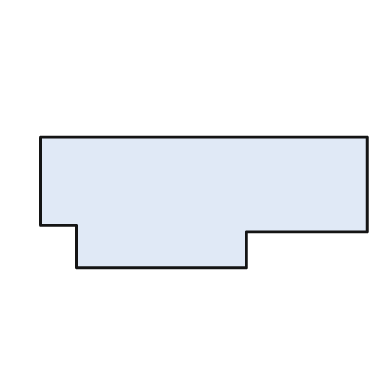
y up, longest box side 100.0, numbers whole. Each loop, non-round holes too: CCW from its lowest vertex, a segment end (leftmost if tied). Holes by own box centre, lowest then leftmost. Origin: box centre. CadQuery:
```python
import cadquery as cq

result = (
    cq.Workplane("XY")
    .moveTo(-39.0, -20.0)
    .lineTo(13.0, -20.0)
    .lineTo(13.0, -9.0)
    .lineTo(50.0, -9.0)
    .lineTo(50.0, 20.0)
    .lineTo(-50.0, 20.0)
    .lineTo(-50.0, -7.0)
    .lineTo(-39.0, -7.0)
    .close()
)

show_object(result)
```